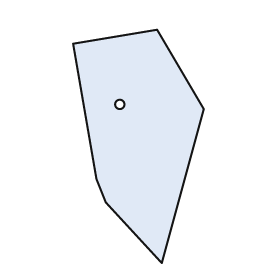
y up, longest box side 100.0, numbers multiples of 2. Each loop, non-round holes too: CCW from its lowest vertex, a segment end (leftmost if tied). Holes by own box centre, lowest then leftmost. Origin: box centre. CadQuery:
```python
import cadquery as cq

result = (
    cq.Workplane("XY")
    .moveTo(10.0, -50.0)
    .lineTo(28.0, 16.0)
    .lineTo(8.0, 50.0)
    .lineTo(-28.0, 44.0)
    .lineTo(-18.0, -14.0)
    .lineTo(-14.0, -24.0)
    .close()
    .moveTo(-8.0, 18.0)
    .circle(2.0)
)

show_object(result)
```